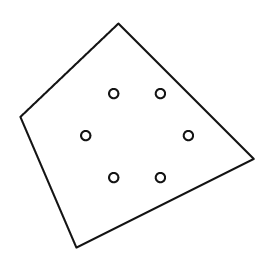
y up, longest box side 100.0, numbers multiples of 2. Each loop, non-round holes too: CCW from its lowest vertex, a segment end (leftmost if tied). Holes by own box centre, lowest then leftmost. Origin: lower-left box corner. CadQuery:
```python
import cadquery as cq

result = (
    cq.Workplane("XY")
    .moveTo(24.0, 0.0)
    .lineTo(100.0, 38.0)
    .lineTo(42.0, 96.0)
    .lineTo(0.0, 56.0)
    .close()
    .moveTo(40.0, 30.0)
    .circle(2.0)
    .moveTo(60.0, 30.0)
    .circle(2.0)
    .moveTo(28.0, 48.0)
    .circle(2.0)
    .moveTo(72.0, 48.0)
    .circle(2.0)
    .moveTo(40.0, 66.0)
    .circle(2.0)
    .moveTo(60.0, 66.0)
    .circle(2.0)
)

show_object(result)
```